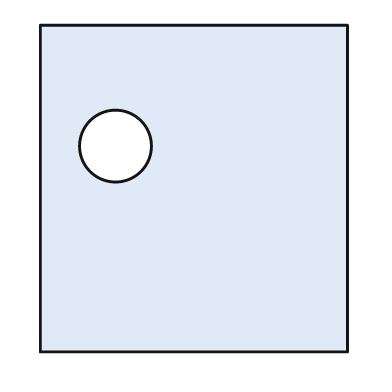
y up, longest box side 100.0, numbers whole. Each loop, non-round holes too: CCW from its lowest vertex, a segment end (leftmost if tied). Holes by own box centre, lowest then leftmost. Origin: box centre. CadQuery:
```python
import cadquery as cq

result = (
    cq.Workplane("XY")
    .moveTo(-47.0, -50.0)
    .lineTo(47.0, -50.0)
    .lineTo(47.0, 50.0)
    .lineTo(-47.0, 50.0)
    .close()
    .moveTo(-24.0, 13.0)
    .circle(11.0)
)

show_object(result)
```